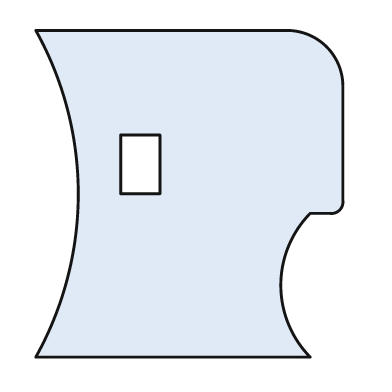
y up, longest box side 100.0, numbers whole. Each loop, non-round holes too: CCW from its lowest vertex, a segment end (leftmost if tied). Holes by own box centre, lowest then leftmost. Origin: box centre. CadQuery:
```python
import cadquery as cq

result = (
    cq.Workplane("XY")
    .moveTo(-47.0, -50.0)
    .lineTo(37.0, -50.0)
    .threePointArc((28.0, -28.0), (37.0, -6.0))
    .lineTo(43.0, -6.0)
    .threePointArc((46.0, -5.0), (47.0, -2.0))
    .lineTo(47.0, 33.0)
    .threePointArc((42.0, 45.0), (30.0, 50.0))
    .lineTo(-47.0, 50.0)
    .threePointArc((-34.0, 0.0), (-47.0, -50.0))
    .close()
    .moveTo(-21.0, 0.0)
    .lineTo(-9.0, 0.0)
    .lineTo(-9.0, 18.0)
    .lineTo(-21.0, 18.0)
    .close()
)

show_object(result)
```